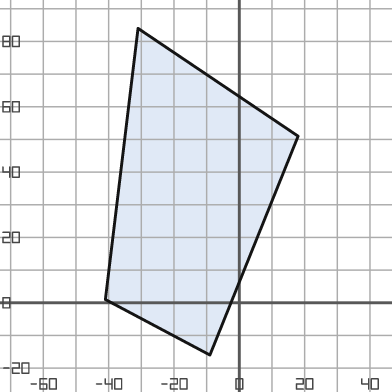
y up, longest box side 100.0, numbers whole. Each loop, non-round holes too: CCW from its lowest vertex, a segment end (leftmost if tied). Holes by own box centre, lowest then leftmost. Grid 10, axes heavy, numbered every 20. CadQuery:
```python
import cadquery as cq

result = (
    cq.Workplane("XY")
    .moveTo(-9.0, -16.0)
    .lineTo(18.0, 51.0)
    .lineTo(-31.0, 84.0)
    .lineTo(-41.0, 1.0)
    .close()
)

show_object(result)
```